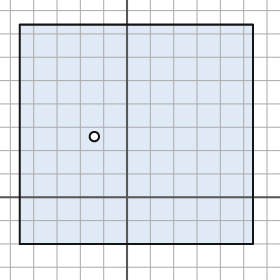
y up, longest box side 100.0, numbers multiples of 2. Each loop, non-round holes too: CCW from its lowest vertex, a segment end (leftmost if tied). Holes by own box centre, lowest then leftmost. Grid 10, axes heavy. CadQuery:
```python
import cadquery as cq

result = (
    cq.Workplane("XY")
    .moveTo(-46.0, -20.0)
    .lineTo(54.0, -20.0)
    .lineTo(54.0, 74.0)
    .lineTo(-46.0, 74.0)
    .close()
    .moveTo(-14.0, 26.0)
    .circle(2.0)
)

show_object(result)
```